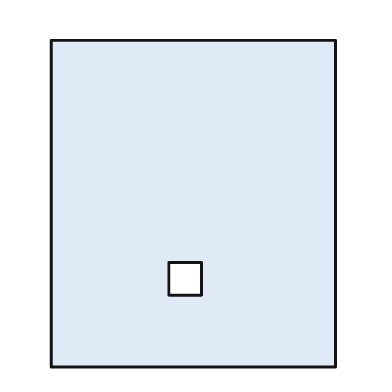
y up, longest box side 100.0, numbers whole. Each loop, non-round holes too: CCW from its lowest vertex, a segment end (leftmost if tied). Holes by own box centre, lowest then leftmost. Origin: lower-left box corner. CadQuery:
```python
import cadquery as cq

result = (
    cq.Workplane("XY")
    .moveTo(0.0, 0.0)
    .lineTo(87.0, 0.0)
    .lineTo(87.0, 100.0)
    .lineTo(0.0, 100.0)
    .close()
    .moveTo(36.0, 22.0)
    .lineTo(46.0, 22.0)
    .lineTo(46.0, 32.0)
    .lineTo(36.0, 32.0)
    .close()
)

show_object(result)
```